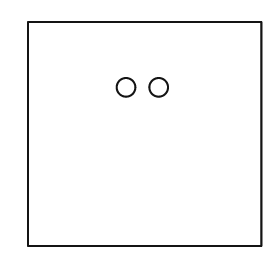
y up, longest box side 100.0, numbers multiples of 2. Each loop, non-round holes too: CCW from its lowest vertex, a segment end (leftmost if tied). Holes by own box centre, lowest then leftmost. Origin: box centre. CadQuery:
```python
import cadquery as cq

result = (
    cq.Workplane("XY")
    .moveTo(-50.0, -48.0)
    .lineTo(50.0, -48.0)
    .lineTo(50.0, 48.0)
    .lineTo(-50.0, 48.0)
    .close()
    .moveTo(-8.0, 20.0)
    .circle(4.0)
    .moveTo(6.0, 20.0)
    .circle(4.0)
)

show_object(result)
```